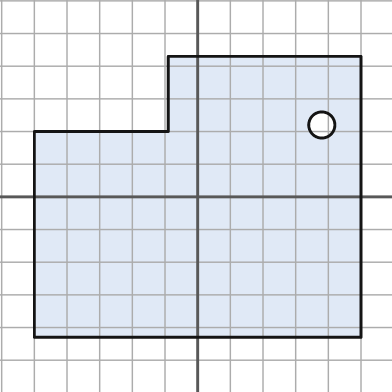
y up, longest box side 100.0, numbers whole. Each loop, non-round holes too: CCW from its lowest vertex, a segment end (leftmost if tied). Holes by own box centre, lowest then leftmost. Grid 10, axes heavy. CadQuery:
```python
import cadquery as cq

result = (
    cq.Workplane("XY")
    .moveTo(-50.0, -43.0)
    .lineTo(50.0, -43.0)
    .lineTo(50.0, 43.0)
    .lineTo(-9.0, 43.0)
    .lineTo(-9.0, 20.0)
    .lineTo(-50.0, 20.0)
    .close()
    .moveTo(38.0, 22.0)
    .circle(4.0)
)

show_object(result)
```